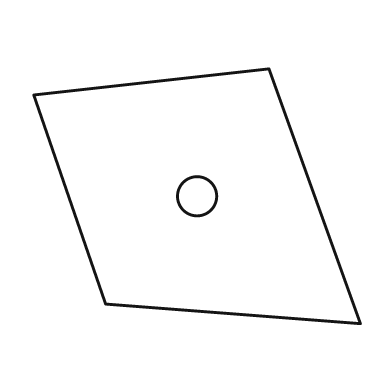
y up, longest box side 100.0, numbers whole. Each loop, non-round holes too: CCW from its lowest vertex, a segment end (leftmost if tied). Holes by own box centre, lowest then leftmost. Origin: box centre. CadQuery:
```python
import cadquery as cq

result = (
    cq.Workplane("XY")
    .moveTo(50.0, -39.0)
    .lineTo(22.0, 39.0)
    .lineTo(-50.0, 31.0)
    .lineTo(-28.0, -33.0)
    .close()
    .moveTo(0.0, 0.0)
    .circle(6.0)
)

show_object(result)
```